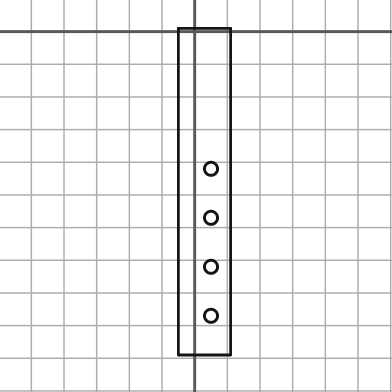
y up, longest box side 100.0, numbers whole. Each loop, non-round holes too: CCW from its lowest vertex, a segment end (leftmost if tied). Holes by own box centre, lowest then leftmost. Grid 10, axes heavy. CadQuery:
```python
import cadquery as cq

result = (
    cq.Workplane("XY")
    .moveTo(-5.0, -99.0)
    .lineTo(11.0, -99.0)
    .lineTo(11.0, 1.0)
    .lineTo(-5.0, 1.0)
    .close()
    .moveTo(5.0, -87.0)
    .circle(2.0)
    .moveTo(5.0, -72.0)
    .circle(2.0)
    .moveTo(5.0, -57.0)
    .circle(2.0)
    .moveTo(5.0, -42.0)
    .circle(2.0)
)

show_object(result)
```